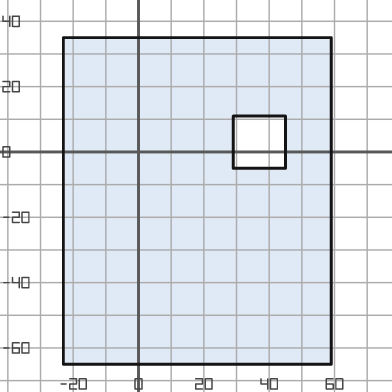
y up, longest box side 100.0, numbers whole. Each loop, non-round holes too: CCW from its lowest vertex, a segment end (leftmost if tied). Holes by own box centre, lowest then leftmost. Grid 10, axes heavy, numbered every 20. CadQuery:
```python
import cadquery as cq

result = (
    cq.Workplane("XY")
    .moveTo(-23.0, -65.0)
    .lineTo(59.0, -65.0)
    .lineTo(59.0, 35.0)
    .lineTo(-23.0, 35.0)
    .close()
    .moveTo(29.0, -5.0)
    .lineTo(45.0, -5.0)
    .lineTo(45.0, 11.0)
    .lineTo(29.0, 11.0)
    .close()
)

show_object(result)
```